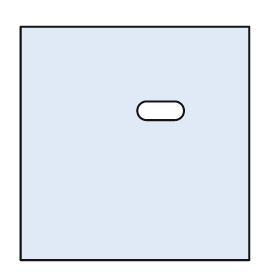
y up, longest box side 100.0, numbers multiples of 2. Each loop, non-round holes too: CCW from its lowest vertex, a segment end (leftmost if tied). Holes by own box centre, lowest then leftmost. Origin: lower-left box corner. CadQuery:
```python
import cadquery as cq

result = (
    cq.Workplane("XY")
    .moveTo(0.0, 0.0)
    .lineTo(98.0, 0.0)
    .lineTo(98.0, 100.0)
    .lineTo(0.0, 100.0)
    .close()
    .moveTo(54.0, 60.0)
    .lineTo(66.0, 60.0)
    .threePointArc((70.0, 64.0), (66.0, 68.0))
    .lineTo(54.0, 68.0)
    .threePointArc((50.0, 64.0), (54.0, 60.0))
    .close()
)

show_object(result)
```